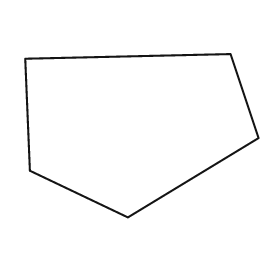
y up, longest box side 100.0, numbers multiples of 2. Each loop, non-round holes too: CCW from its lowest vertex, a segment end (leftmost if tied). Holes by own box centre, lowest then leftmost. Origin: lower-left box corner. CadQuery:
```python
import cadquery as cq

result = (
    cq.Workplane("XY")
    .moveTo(44.0, 0.0)
    .lineTo(100.0, 34.0)
    .lineTo(88.0, 70.0)
    .lineTo(0.0, 68.0)
    .lineTo(2.0, 20.0)
    .close()
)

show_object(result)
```